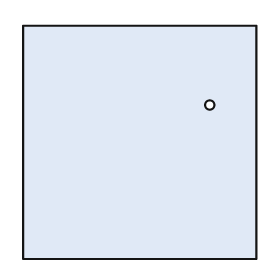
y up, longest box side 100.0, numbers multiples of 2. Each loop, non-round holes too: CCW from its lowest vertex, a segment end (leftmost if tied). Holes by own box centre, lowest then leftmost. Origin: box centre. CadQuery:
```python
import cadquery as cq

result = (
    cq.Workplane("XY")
    .moveTo(-50.0, -50.0)
    .lineTo(50.0, -50.0)
    .lineTo(50.0, 50.0)
    .lineTo(-50.0, 50.0)
    .close()
    .moveTo(30.0, 16.0)
    .circle(2.0)
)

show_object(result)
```